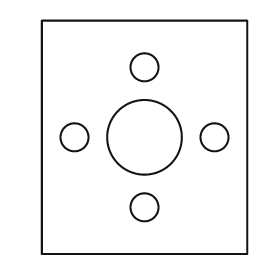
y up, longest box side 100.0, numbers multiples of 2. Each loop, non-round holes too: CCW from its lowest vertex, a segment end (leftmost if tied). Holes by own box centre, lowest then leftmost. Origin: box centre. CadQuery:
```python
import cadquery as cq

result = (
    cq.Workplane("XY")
    .moveTo(-44.0, -50.0)
    .lineTo(44.0, -50.0)
    .lineTo(44.0, 50.0)
    .lineTo(-44.0, 50.0)
    .close()
    .moveTo(0.0, -30.0)
    .circle(6.0)
    .moveTo(-30.0, 0.0)
    .circle(6.0)
    .moveTo(0.0, 0.0)
    .circle(16.0)
    .moveTo(30.0, 0.0)
    .circle(6.0)
    .moveTo(0.0, 30.0)
    .circle(6.0)
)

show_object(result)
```